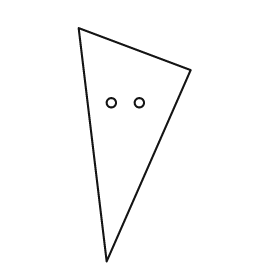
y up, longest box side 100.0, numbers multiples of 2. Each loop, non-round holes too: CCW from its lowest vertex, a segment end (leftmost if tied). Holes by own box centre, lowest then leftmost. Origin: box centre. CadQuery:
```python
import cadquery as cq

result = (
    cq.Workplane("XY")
    .moveTo(-12.0, -50.0)
    .lineTo(24.0, 32.0)
    .lineTo(-24.0, 50.0)
    .close()
    .moveTo(-10.0, 18.0)
    .circle(2.0)
    .moveTo(2.0, 18.0)
    .circle(2.0)
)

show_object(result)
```